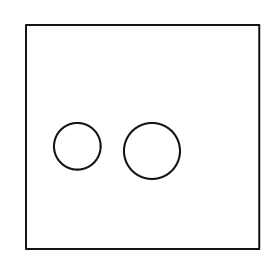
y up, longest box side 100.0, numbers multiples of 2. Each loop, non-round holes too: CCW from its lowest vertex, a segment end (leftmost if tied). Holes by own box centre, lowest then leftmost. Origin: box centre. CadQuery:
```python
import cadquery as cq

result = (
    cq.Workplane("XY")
    .moveTo(-50.0, -48.0)
    .lineTo(50.0, -48.0)
    .lineTo(50.0, 48.0)
    .lineTo(-50.0, 48.0)
    .close()
    .moveTo(4.0, -6.0)
    .circle(12.0)
    .moveTo(-28.0, -4.0)
    .circle(10.0)
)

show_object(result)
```